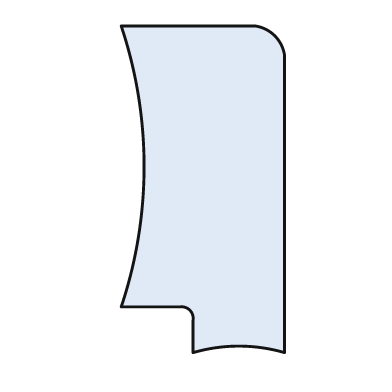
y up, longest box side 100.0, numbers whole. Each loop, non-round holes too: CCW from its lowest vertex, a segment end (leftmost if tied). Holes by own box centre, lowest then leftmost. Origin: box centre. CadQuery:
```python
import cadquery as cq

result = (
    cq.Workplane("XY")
    .moveTo(-3.0, -50.0)
    .threePointArc((11.0, -48.0), (25.0, -50.0))
    .lineTo(25.0, 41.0)
    .threePointArc((22.0, 47.0), (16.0, 50.0))
    .lineTo(-25.0, 50.0)
    .threePointArc((-18.0, 7.0), (-25.0, -36.0))
    .lineTo(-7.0, -36.0)
    .threePointArc((-4.0, -37.0), (-3.0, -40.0))
    .close()
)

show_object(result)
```